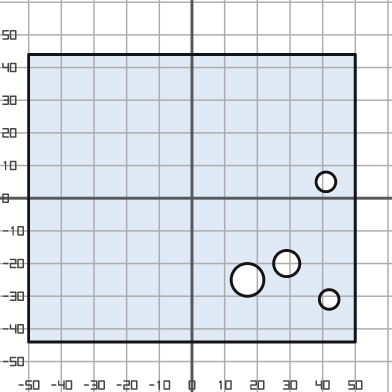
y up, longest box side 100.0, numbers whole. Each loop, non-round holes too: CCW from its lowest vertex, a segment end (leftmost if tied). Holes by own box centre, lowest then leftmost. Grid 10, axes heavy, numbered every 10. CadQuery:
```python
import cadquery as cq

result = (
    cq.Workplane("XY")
    .moveTo(-50.0, -44.0)
    .lineTo(50.0, -44.0)
    .lineTo(50.0, 44.0)
    .lineTo(-50.0, 44.0)
    .close()
    .moveTo(42.0, -31.0)
    .circle(3.0)
    .moveTo(17.0, -25.0)
    .circle(5.0)
    .moveTo(29.0, -20.0)
    .circle(4.0)
    .moveTo(41.0, 5.0)
    .circle(3.0)
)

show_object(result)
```